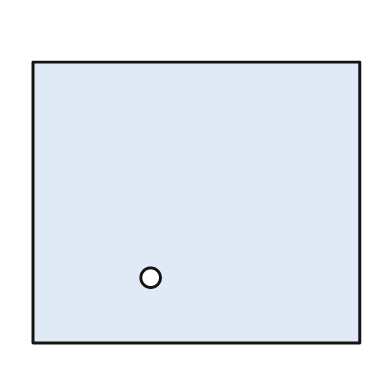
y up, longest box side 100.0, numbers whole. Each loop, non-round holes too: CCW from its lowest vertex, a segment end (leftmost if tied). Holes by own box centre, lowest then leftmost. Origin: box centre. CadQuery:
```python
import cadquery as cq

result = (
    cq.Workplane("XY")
    .moveTo(-50.0, -43.0)
    .lineTo(50.0, -43.0)
    .lineTo(50.0, 43.0)
    .lineTo(-50.0, 43.0)
    .close()
    .moveTo(-14.0, -23.0)
    .circle(3.0)
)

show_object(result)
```